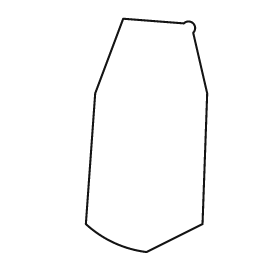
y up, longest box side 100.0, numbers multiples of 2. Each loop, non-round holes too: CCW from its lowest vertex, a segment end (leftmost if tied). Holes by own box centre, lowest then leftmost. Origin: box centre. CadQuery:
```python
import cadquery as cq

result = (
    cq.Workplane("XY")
    .moveTo(0.0, -50.0)
    .lineTo(24.0, -38.0)
    .lineTo(26.0, 18.0)
    .lineTo(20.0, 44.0)
    .threePointArc((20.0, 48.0), (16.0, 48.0))
    .lineTo(-10.0, 50.0)
    .lineTo(-22.0, 18.0)
    .lineTo(-26.0, -38.0)
    .threePointArc((-14.0, -46.0), (0.0, -50.0))
    .close()
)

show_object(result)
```